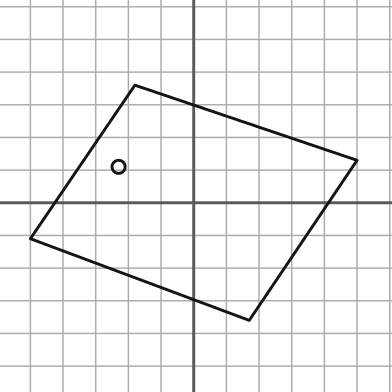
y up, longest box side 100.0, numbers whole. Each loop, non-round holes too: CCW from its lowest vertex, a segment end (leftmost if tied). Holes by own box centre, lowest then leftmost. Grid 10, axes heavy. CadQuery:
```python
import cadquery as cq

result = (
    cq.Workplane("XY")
    .moveTo(17.0, -36.0)
    .lineTo(50.0, 13.0)
    .lineTo(-18.0, 36.0)
    .lineTo(-50.0, -11.0)
    .close()
    .moveTo(-23.0, 11.0)
    .circle(2.0)
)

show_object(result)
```